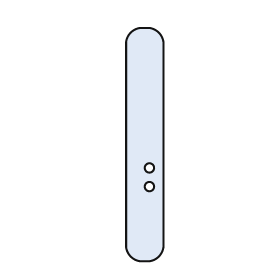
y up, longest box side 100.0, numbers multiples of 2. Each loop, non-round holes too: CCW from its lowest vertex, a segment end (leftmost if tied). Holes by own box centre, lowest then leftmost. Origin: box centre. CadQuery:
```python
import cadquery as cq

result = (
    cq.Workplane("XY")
    .moveTo(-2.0, -50.0)
    .lineTo(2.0, -50.0)
    .threePointArc((6.0, -48.0), (8.0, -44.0))
    .lineTo(8.0, 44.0)
    .threePointArc((6.0, 48.0), (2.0, 50.0))
    .lineTo(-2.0, 50.0)
    .threePointArc((-6.0, 48.0), (-8.0, 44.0))
    .lineTo(-8.0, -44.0)
    .threePointArc((-6.0, -48.0), (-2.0, -50.0))
    .close()
    .moveTo(2.0, -18.0)
    .circle(2.0)
    .moveTo(2.0, -10.0)
    .circle(2.0)
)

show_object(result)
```